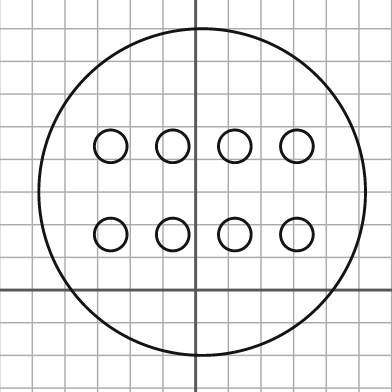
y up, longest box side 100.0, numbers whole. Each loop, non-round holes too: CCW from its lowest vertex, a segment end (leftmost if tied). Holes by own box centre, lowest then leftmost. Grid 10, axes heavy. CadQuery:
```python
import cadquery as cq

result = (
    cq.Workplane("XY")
    .moveTo(2.0, 30.0)
    .circle(50.0)
    .moveTo(-26.0, 17.0)
    .circle(5.0)
    .moveTo(-7.0, 17.0)
    .circle(5.0)
    .moveTo(12.0, 17.0)
    .circle(5.0)
    .moveTo(31.0, 17.0)
    .circle(5.0)
    .moveTo(-26.0, 44.0)
    .circle(5.0)
    .moveTo(-7.0, 44.0)
    .circle(5.0)
    .moveTo(12.0, 44.0)
    .circle(5.0)
    .moveTo(31.0, 44.0)
    .circle(5.0)
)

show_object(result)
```